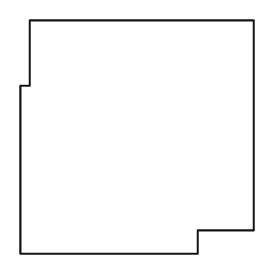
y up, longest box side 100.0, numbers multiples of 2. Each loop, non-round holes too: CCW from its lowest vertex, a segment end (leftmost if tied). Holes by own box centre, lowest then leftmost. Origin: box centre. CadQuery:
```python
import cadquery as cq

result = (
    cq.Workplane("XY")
    .moveTo(-50.0, -50.0)
    .lineTo(26.0, -50.0)
    .lineTo(26.0, -40.0)
    .lineTo(50.0, -40.0)
    .lineTo(50.0, 50.0)
    .lineTo(-46.0, 50.0)
    .lineTo(-46.0, 22.0)
    .lineTo(-50.0, 22.0)
    .close()
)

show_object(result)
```